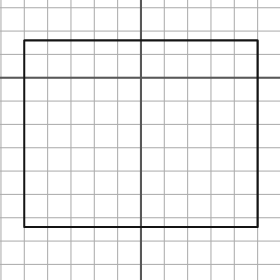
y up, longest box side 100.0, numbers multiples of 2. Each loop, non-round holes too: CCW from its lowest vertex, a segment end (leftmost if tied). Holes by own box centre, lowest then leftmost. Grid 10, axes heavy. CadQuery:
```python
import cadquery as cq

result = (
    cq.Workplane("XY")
    .moveTo(-50.0, -64.0)
    .lineTo(50.0, -64.0)
    .lineTo(50.0, 16.0)
    .lineTo(-50.0, 16.0)
    .close()
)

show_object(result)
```